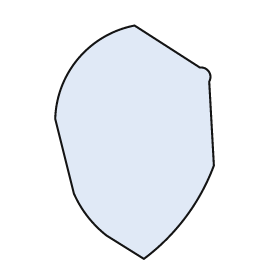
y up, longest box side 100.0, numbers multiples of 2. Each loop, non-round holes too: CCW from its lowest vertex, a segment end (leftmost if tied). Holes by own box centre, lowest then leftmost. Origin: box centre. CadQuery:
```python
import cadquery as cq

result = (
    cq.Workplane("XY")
    .moveTo(4.0, -50.0)
    .threePointArc((22.0, -32.0), (34.0, -10.0))
    .lineTo(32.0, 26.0)
    .threePointArc((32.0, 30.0), (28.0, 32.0))
    .lineTo(0.0, 50.0)
    .threePointArc((-24.0, 36.0), (-34.0, 10.0))
    .lineTo(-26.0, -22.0)
    .threePointArc((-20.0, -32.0), (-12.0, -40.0))
    .close()
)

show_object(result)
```